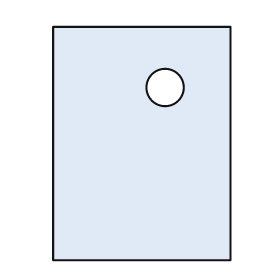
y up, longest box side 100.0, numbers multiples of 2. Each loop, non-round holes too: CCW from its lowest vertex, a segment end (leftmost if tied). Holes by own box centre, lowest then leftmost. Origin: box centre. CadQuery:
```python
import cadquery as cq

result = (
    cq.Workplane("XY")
    .moveTo(-38.0, -50.0)
    .lineTo(38.0, -50.0)
    .lineTo(38.0, 50.0)
    .lineTo(-38.0, 50.0)
    .close()
    .moveTo(10.0, 24.0)
    .circle(8.0)
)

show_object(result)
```